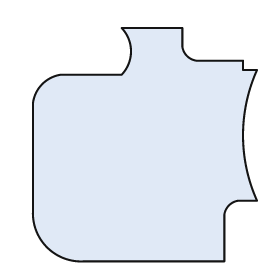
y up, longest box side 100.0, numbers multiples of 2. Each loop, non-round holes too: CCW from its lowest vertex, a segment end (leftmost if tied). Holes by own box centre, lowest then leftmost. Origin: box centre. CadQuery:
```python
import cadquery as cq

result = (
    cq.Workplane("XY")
    .moveTo(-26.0, -50.0)
    .lineTo(34.0, -50.0)
    .lineTo(34.0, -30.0)
    .threePointArc((36.0, -26.0), (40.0, -24.0))
    .lineTo(48.0, -24.0)
    .threePointArc((42.0, 4.0), (48.0, 32.0))
    .lineTo(42.0, 32.0)
    .lineTo(42.0, 36.0)
    .lineTo(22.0, 36.0)
    .threePointArc((18.0, 38.0), (16.0, 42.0))
    .lineTo(16.0, 50.0)
    .lineTo(-10.0, 50.0)
    .threePointArc((-6.0, 40.0), (-10.0, 30.0))
    .lineTo(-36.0, 30.0)
    .threePointArc((-44.0, 26.0), (-48.0, 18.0))
    .lineTo(-48.0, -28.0)
    .threePointArc((-42.0, -44.0), (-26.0, -50.0))
    .close()
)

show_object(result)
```